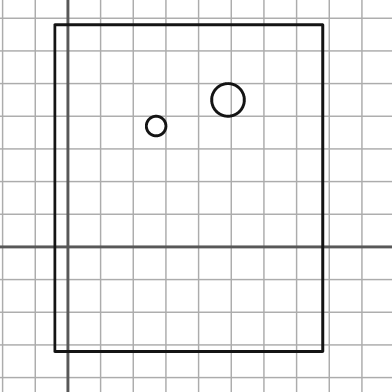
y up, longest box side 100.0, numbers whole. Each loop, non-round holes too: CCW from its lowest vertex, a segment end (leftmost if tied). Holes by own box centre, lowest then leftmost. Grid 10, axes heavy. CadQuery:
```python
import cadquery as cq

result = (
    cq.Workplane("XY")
    .moveTo(-4.0, -32.0)
    .lineTo(78.0, -32.0)
    .lineTo(78.0, 68.0)
    .lineTo(-4.0, 68.0)
    .close()
    .moveTo(27.0, 37.0)
    .circle(3.0)
    .moveTo(49.0, 45.0)
    .circle(5.0)
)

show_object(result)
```